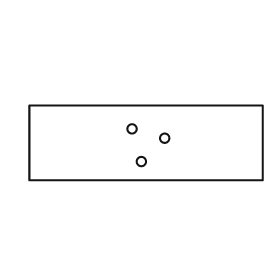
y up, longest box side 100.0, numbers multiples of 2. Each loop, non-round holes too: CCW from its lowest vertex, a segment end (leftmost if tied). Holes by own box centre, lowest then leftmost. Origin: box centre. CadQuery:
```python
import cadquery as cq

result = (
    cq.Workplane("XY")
    .moveTo(-50.0, -16.0)
    .lineTo(50.0, -16.0)
    .lineTo(50.0, 16.0)
    .lineTo(-50.0, 16.0)
    .close()
    .moveTo(-2.0, -8.0)
    .circle(2.0)
    .moveTo(8.0, 2.0)
    .circle(2.0)
    .moveTo(-6.0, 6.0)
    .circle(2.0)
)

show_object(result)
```